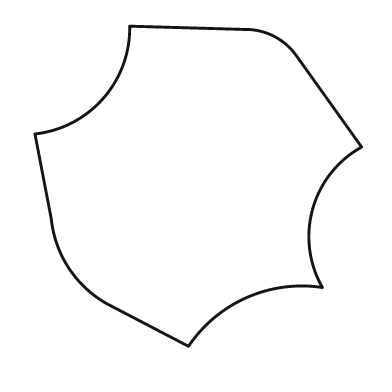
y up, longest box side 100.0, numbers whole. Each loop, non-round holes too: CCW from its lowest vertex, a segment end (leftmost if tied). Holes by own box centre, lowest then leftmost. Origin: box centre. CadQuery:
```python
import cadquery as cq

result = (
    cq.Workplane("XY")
    .moveTo(-3.0, -49.0)
    .threePointArc((15.0, -34.0), (38.0, -31.0))
    .threePointArc((35.0, -7.0), (50.0, 12.0))
    .lineTo(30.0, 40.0)
    .threePointArc((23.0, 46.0), (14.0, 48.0))
    .lineTo(-21.0, 49.0)
    .threePointArc((-29.0, 27.0), (-50.0, 16.0))
    .lineTo(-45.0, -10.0)
    .threePointArc((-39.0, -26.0), (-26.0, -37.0))
    .close()
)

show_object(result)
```